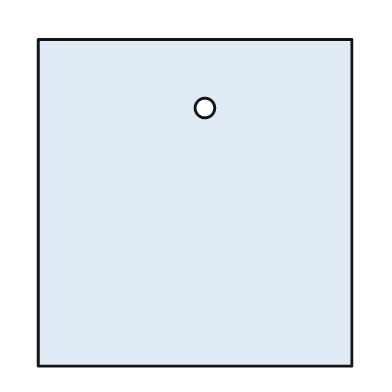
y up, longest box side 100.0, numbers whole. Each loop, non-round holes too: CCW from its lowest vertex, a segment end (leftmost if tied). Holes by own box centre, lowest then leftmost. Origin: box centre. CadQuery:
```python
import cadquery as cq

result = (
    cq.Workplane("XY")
    .moveTo(-48.0, -50.0)
    .lineTo(48.0, -50.0)
    .lineTo(48.0, 50.0)
    .lineTo(-48.0, 50.0)
    .close()
    .moveTo(3.0, 29.0)
    .circle(3.0)
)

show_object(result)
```